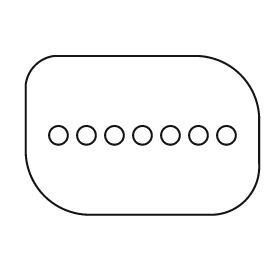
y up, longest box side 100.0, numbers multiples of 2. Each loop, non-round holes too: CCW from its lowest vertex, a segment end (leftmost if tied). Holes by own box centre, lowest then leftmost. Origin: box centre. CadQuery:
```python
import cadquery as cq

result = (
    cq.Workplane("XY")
    .moveTo(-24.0, -34.0)
    .lineTo(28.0, -34.0)
    .threePointArc((44.0, -28.0), (50.0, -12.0))
    .lineTo(50.0, 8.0)
    .threePointArc((42.0, 26.0), (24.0, 34.0))
    .lineTo(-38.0, 34.0)
    .threePointArc((-46.0, 30.0), (-50.0, 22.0))
    .lineTo(-50.0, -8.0)
    .threePointArc((-42.0, -26.0), (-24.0, -34.0))
    .close()
    .moveTo(-36.0, 0.0)
    .circle(4.0)
    .moveTo(-24.0, 0.0)
    .circle(4.0)
    .moveTo(-12.0, 0.0)
    .circle(4.0)
    .moveTo(0.0, 0.0)
    .circle(4.0)
    .moveTo(12.0, 0.0)
    .circle(4.0)
    .moveTo(24.0, 0.0)
    .circle(4.0)
    .moveTo(36.0, 0.0)
    .circle(4.0)
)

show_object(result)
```